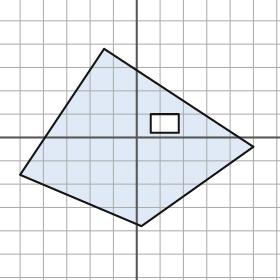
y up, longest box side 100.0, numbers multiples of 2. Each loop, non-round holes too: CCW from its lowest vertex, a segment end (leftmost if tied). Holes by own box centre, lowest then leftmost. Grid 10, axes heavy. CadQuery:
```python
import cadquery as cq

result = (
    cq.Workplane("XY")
    .moveTo(2.0, -38.0)
    .lineTo(50.0, -4.0)
    .lineTo(-14.0, 38.0)
    .lineTo(-50.0, -16.0)
    .close()
    .moveTo(6.0, 2.0)
    .lineTo(18.0, 2.0)
    .lineTo(18.0, 10.0)
    .lineTo(6.0, 10.0)
    .close()
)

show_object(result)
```